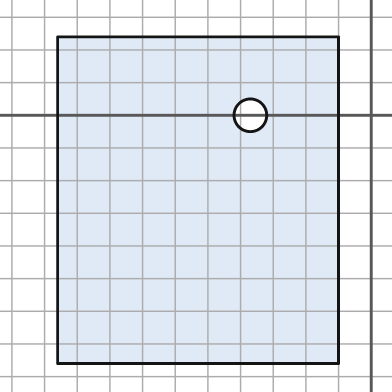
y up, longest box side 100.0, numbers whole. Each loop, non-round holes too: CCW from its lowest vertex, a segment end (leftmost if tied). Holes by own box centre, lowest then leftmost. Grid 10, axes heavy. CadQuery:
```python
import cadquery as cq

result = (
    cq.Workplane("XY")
    .moveTo(-96.0, -76.0)
    .lineTo(-10.0, -76.0)
    .lineTo(-10.0, 24.0)
    .lineTo(-96.0, 24.0)
    .close()
    .moveTo(-37.0, 0.0)
    .circle(5.0)
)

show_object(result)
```